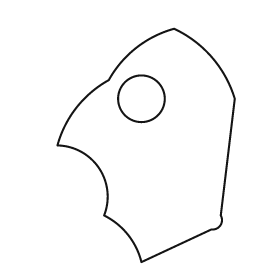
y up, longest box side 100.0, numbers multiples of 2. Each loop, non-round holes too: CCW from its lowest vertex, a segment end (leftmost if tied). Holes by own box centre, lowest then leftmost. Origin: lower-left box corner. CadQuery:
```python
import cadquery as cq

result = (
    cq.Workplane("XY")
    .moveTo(36.0, 0.0)
    .lineTo(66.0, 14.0)
    .threePointArc((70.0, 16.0), (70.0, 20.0))
    .lineTo(76.0, 70.0)
    .threePointArc((66.0, 88.0), (50.0, 100.0))
    .threePointArc((34.0, 92.0), (22.0, 78.0))
    .threePointArc((8.0, 66.0), (0.0, 50.0))
    .threePointArc((18.0, 40.0), (20.0, 20.0))
    .threePointArc((30.0, 12.0), (36.0, 0.0))
    .close()
    .moveTo(36.0, 70.0)
    .circle(10.0)
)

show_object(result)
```